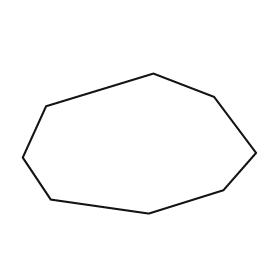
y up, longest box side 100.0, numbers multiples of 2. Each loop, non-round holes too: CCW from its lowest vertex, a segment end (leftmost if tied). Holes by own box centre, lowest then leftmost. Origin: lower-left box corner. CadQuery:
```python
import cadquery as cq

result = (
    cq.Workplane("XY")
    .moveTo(54.0, 0.0)
    .lineTo(86.0, 10.0)
    .lineTo(100.0, 26.0)
    .lineTo(82.0, 50.0)
    .lineTo(56.0, 60.0)
    .lineTo(10.0, 46.0)
    .lineTo(0.0, 24.0)
    .lineTo(12.0, 6.0)
    .close()
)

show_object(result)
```